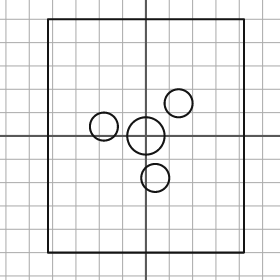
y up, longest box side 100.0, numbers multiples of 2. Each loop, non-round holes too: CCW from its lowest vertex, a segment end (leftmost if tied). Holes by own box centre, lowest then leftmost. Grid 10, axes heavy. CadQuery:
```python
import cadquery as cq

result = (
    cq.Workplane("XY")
    .moveTo(-42.0, -50.0)
    .lineTo(42.0, -50.0)
    .lineTo(42.0, 50.0)
    .lineTo(-42.0, 50.0)
    .close()
    .moveTo(4.0, -18.0)
    .circle(6.0)
    .moveTo(0.0, 0.0)
    .circle(8.0)
    .moveTo(-18.0, 4.0)
    .circle(6.0)
    .moveTo(14.0, 14.0)
    .circle(6.0)
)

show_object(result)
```